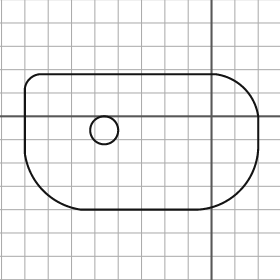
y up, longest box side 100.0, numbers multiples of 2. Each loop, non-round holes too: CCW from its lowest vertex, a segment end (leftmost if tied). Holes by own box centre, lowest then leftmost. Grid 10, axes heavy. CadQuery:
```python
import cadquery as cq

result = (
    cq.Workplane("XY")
    .moveTo(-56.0, -40.0)
    .lineTo(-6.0, -40.0)
    .threePointArc((12.0, -32.0), (20.0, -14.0))
    .lineTo(20.0, 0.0)
    .threePointArc((14.0, 12.0), (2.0, 18.0))
    .lineTo(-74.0, 18.0)
    .threePointArc((-78.0, 16.0), (-80.0, 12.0))
    .lineTo(-80.0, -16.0)
    .threePointArc((-72.0, -32.0), (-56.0, -40.0))
    .close()
    .moveTo(-46.0, -6.0)
    .circle(6.0)
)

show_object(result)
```